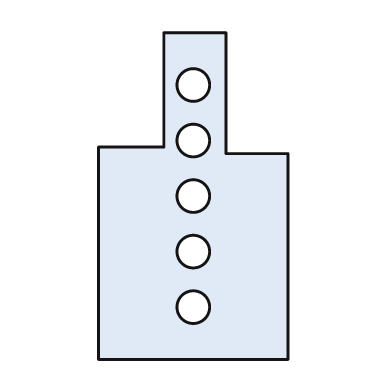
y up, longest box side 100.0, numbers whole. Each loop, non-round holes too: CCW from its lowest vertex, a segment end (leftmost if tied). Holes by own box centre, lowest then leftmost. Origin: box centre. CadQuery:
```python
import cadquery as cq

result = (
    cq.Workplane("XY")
    .moveTo(-29.0, -50.0)
    .lineTo(29.0, -50.0)
    .lineTo(29.0, 13.0)
    .lineTo(10.0, 13.0)
    .lineTo(10.0, 50.0)
    .lineTo(-9.0, 50.0)
    .lineTo(-9.0, 15.0)
    .lineTo(-29.0, 15.0)
    .close()
    .moveTo(0.0, -34.0)
    .circle(5.0)
    .moveTo(0.0, -17.0)
    .circle(5.0)
    .moveTo(0.0, 0.0)
    .circle(5.0)
    .moveTo(0.0, 17.0)
    .circle(5.0)
    .moveTo(0.0, 34.0)
    .circle(5.0)
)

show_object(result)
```